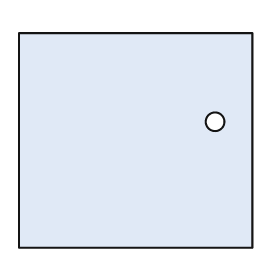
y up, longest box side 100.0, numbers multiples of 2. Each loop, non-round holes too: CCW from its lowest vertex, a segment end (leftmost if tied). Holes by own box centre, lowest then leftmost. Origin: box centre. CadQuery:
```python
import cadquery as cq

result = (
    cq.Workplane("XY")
    .moveTo(-50.0, -46.0)
    .lineTo(50.0, -46.0)
    .lineTo(50.0, 46.0)
    .lineTo(-50.0, 46.0)
    .close()
    .moveTo(34.0, 8.0)
    .circle(4.0)
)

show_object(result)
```